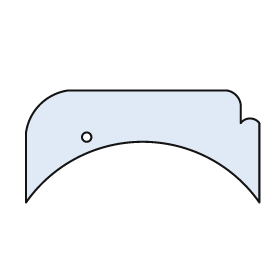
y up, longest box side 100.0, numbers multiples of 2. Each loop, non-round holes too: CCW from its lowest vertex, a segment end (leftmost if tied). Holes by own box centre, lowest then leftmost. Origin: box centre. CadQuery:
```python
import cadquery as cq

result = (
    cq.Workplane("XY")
    .moveTo(-50.0, -24.0)
    .threePointArc((0.0, 2.0), (50.0, -24.0))
    .lineTo(50.0, 10.0)
    .threePointArc((46.0, 12.0), (42.0, 10.0))
    .lineTo(42.0, 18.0)
    .threePointArc((40.0, 22.0), (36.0, 24.0))
    .lineTo(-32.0, 24.0)
    .threePointArc((-44.0, 18.0), (-50.0, 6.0))
    .close()
    .moveTo(-24.0, 4.0)
    .circle(2.0)
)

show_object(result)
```